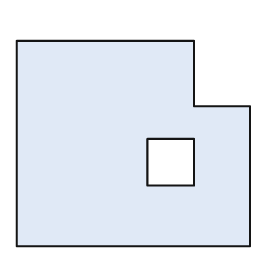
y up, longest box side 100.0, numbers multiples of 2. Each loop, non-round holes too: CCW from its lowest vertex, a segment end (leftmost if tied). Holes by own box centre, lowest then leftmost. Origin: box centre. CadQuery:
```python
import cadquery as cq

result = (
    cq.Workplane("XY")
    .moveTo(-50.0, -44.0)
    .lineTo(50.0, -44.0)
    .lineTo(50.0, 16.0)
    .lineTo(26.0, 16.0)
    .lineTo(26.0, 44.0)
    .lineTo(-50.0, 44.0)
    .close()
    .moveTo(6.0, -18.0)
    .lineTo(26.0, -18.0)
    .lineTo(26.0, 2.0)
    .lineTo(6.0, 2.0)
    .close()
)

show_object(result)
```